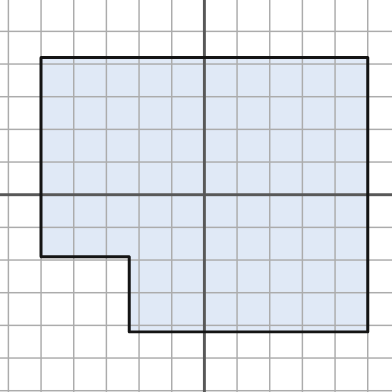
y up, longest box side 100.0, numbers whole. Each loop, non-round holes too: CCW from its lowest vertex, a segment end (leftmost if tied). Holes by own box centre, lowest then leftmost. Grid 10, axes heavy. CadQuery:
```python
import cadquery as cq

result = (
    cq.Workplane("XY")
    .moveTo(-23.0, -42.0)
    .lineTo(50.0, -42.0)
    .lineTo(50.0, 42.0)
    .lineTo(-50.0, 42.0)
    .lineTo(-50.0, -19.0)
    .lineTo(-23.0, -19.0)
    .close()
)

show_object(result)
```